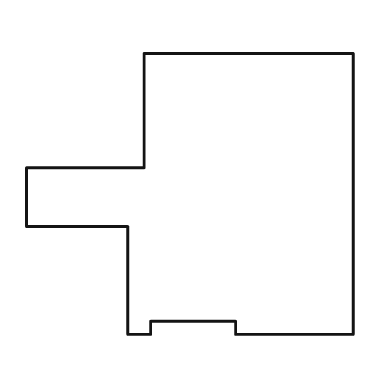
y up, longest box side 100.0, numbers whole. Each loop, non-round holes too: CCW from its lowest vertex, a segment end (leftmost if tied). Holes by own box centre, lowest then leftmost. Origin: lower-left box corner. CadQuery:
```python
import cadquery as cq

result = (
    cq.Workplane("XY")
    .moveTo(31.0, 0.0)
    .lineTo(38.0, 0.0)
    .lineTo(38.0, 4.0)
    .lineTo(64.0, 4.0)
    .lineTo(64.0, 0.0)
    .lineTo(100.0, 0.0)
    .lineTo(100.0, 86.0)
    .lineTo(36.0, 86.0)
    .lineTo(36.0, 51.0)
    .lineTo(0.0, 51.0)
    .lineTo(0.0, 33.0)
    .lineTo(31.0, 33.0)
    .close()
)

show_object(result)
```